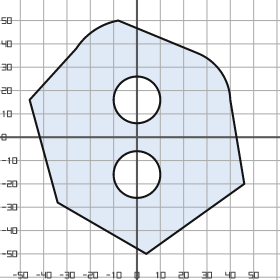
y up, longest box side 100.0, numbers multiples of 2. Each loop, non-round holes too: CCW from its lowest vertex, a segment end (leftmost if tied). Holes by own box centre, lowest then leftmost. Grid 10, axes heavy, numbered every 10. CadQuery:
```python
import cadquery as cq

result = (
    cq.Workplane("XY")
    .moveTo(4.0, -50.0)
    .lineTo(46.0, -20.0)
    .lineTo(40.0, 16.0)
    .threePointArc((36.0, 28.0), (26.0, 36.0))
    .lineTo(-8.0, 50.0)
    .threePointArc((-18.0, 46.0), (-26.0, 38.0))
    .lineTo(-46.0, 16.0)
    .lineTo(-34.0, -28.0)
    .close()
    .moveTo(0.0, -16.0)
    .circle(10.0)
    .moveTo(0.0, 16.0)
    .circle(10.0)
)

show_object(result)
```